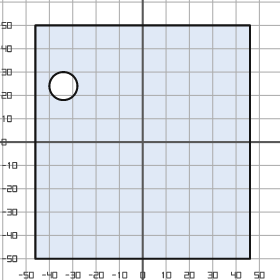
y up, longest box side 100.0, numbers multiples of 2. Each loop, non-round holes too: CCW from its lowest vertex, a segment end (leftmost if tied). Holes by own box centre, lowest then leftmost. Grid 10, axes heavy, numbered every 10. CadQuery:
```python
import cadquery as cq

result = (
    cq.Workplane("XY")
    .moveTo(-46.0, -50.0)
    .lineTo(46.0, -50.0)
    .lineTo(46.0, 50.0)
    .lineTo(-46.0, 50.0)
    .close()
    .moveTo(-34.0, 24.0)
    .circle(6.0)
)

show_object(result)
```